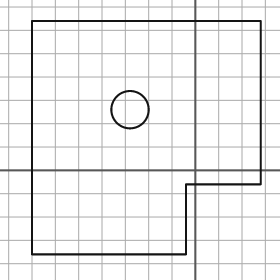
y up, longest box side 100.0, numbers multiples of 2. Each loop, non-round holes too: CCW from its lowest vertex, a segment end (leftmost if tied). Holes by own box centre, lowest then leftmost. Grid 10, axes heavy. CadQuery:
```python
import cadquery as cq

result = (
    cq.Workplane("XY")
    .moveTo(-70.0, -36.0)
    .lineTo(-4.0, -36.0)
    .lineTo(-4.0, -6.0)
    .lineTo(28.0, -6.0)
    .lineTo(28.0, 64.0)
    .lineTo(-70.0, 64.0)
    .close()
    .moveTo(-28.0, 26.0)
    .circle(8.0)
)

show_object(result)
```